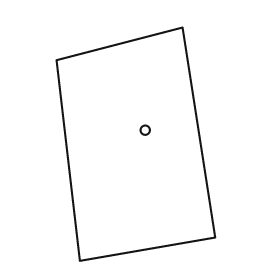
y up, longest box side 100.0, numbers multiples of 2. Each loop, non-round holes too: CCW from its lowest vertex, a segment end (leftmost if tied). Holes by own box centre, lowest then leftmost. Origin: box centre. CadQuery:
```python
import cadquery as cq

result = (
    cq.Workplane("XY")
    .moveTo(-24.0, -50.0)
    .lineTo(34.0, -40.0)
    .lineTo(20.0, 50.0)
    .lineTo(-34.0, 36.0)
    .close()
    .moveTo(4.0, 6.0)
    .circle(2.0)
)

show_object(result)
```